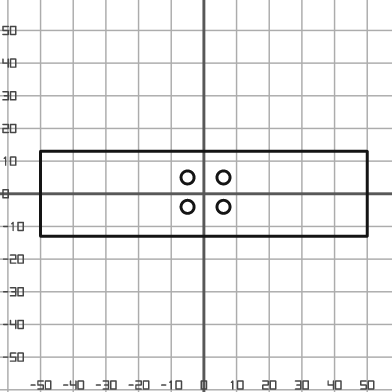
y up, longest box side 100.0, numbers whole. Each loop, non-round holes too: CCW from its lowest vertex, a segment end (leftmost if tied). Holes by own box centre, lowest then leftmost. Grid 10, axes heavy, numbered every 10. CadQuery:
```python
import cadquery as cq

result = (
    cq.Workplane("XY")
    .moveTo(-50.0, -13.0)
    .lineTo(50.0, -13.0)
    .lineTo(50.0, 13.0)
    .lineTo(-50.0, 13.0)
    .close()
    .moveTo(-5.0, -4.0)
    .circle(2.0)
    .moveTo(6.0, -4.0)
    .circle(2.0)
    .moveTo(-5.0, 5.0)
    .circle(2.0)
    .moveTo(6.0, 5.0)
    .circle(2.0)
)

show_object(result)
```